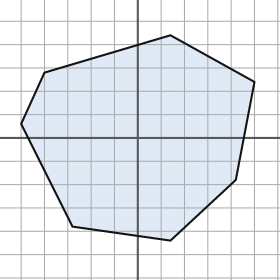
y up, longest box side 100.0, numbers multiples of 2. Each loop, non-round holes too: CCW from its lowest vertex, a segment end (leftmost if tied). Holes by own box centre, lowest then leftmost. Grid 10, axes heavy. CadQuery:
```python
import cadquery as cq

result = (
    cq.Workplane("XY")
    .moveTo(14.0, -44.0)
    .lineTo(42.0, -18.0)
    .lineTo(50.0, 24.0)
    .lineTo(14.0, 44.0)
    .lineTo(-40.0, 28.0)
    .lineTo(-50.0, 6.0)
    .lineTo(-28.0, -38.0)
    .close()
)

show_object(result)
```